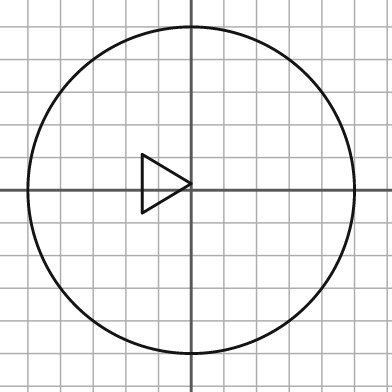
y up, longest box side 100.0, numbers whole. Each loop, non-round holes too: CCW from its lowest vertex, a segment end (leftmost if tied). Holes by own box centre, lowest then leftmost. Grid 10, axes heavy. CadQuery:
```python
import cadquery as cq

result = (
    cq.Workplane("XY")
    .moveTo(0.0, 0.0)
    .circle(50.0)
    .moveTo(-15.0, -7.0)
    .lineTo(0.0, 2.0)
    .lineTo(-15.0, 11.0)
    .close()
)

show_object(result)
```